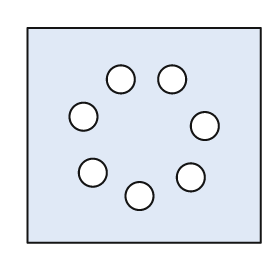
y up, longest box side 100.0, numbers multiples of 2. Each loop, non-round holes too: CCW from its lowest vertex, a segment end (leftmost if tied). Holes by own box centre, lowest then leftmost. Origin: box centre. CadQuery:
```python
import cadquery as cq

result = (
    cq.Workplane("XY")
    .moveTo(-50.0, -46.0)
    .lineTo(50.0, -46.0)
    .lineTo(50.0, 46.0)
    .lineTo(-50.0, 46.0)
    .close()
    .moveTo(-2.0, -26.0)
    .circle(6.0)
    .moveTo(20.0, -18.0)
    .circle(6.0)
    .moveTo(-22.0, -16.0)
    .circle(6.0)
    .moveTo(26.0, 4.0)
    .circle(6.0)
    .moveTo(-26.0, 8.0)
    .circle(6.0)
    .moveTo(-10.0, 24.0)
    .circle(6.0)
    .moveTo(12.0, 24.0)
    .circle(6.0)
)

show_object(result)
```